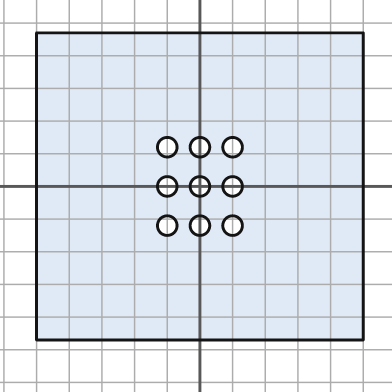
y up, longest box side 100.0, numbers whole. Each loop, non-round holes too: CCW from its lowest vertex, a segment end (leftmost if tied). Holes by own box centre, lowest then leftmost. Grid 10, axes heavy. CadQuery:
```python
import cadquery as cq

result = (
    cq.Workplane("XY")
    .moveTo(-50.0, -47.0)
    .lineTo(50.0, -47.0)
    .lineTo(50.0, 47.0)
    .lineTo(-50.0, 47.0)
    .close()
    .moveTo(-10.0, -12.0)
    .circle(3.0)
    .moveTo(0.0, -12.0)
    .circle(3.0)
    .moveTo(10.0, -12.0)
    .circle(3.0)
    .moveTo(-10.0, 0.0)
    .circle(3.0)
    .moveTo(0.0, 0.0)
    .circle(3.0)
    .moveTo(10.0, 0.0)
    .circle(3.0)
    .moveTo(-10.0, 12.0)
    .circle(3.0)
    .moveTo(0.0, 12.0)
    .circle(3.0)
    .moveTo(10.0, 12.0)
    .circle(3.0)
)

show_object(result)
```